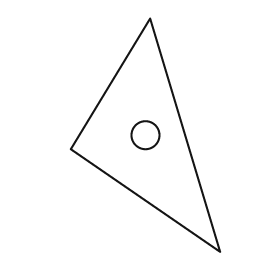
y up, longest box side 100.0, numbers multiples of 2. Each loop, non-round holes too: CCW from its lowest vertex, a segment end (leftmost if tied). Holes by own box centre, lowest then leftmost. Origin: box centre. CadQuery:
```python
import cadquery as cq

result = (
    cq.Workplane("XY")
    .moveTo(32.0, -50.0)
    .lineTo(2.0, 50.0)
    .lineTo(-32.0, -6.0)
    .close()
    .moveTo(0.0, 0.0)
    .circle(6.0)
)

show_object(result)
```